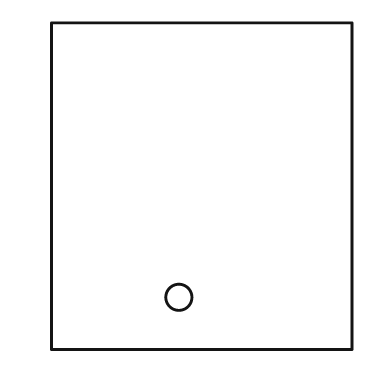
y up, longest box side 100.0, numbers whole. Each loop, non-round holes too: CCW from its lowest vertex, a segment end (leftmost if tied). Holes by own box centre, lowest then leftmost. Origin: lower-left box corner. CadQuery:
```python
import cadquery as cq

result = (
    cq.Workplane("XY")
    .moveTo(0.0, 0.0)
    .lineTo(92.0, 0.0)
    .lineTo(92.0, 100.0)
    .lineTo(0.0, 100.0)
    .close()
    .moveTo(39.0, 16.0)
    .circle(4.0)
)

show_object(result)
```